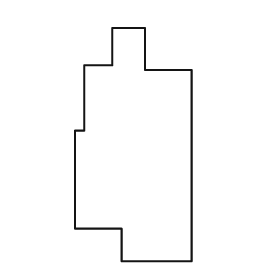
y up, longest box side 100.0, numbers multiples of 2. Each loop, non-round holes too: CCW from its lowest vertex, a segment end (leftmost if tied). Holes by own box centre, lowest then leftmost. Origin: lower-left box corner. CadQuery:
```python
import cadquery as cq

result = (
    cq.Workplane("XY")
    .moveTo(20.0, 0.0)
    .lineTo(50.0, 0.0)
    .lineTo(50.0, 82.0)
    .lineTo(30.0, 82.0)
    .lineTo(30.0, 100.0)
    .lineTo(16.0, 100.0)
    .lineTo(16.0, 84.0)
    .lineTo(4.0, 84.0)
    .lineTo(4.0, 56.0)
    .lineTo(0.0, 56.0)
    .lineTo(0.0, 14.0)
    .lineTo(20.0, 14.0)
    .close()
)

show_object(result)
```